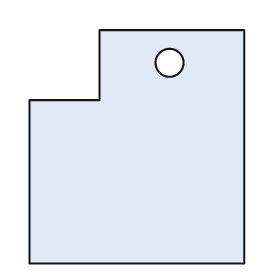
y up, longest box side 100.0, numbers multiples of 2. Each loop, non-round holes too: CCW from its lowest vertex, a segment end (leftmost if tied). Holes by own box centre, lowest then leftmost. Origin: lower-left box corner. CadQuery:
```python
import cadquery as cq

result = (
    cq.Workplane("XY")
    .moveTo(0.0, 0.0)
    .lineTo(92.0, 0.0)
    .lineTo(92.0, 100.0)
    .lineTo(30.0, 100.0)
    .lineTo(30.0, 70.0)
    .lineTo(0.0, 70.0)
    .close()
    .moveTo(60.0, 86.0)
    .circle(6.0)
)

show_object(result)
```